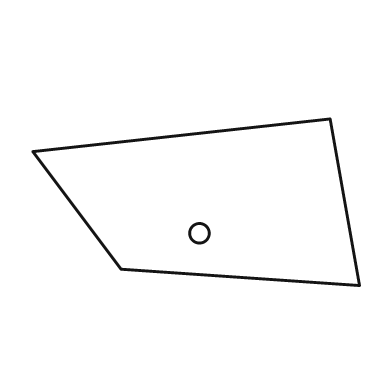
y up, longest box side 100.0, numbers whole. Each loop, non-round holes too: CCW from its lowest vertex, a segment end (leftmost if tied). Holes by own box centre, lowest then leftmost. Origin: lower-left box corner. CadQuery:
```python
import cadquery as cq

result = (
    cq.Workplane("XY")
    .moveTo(100.0, 0.0)
    .lineTo(91.0, 51.0)
    .lineTo(0.0, 41.0)
    .lineTo(27.0, 5.0)
    .close()
    .moveTo(51.0, 16.0)
    .circle(3.0)
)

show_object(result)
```